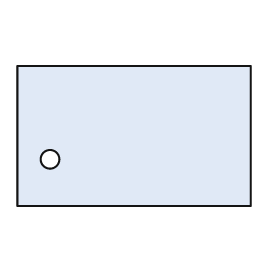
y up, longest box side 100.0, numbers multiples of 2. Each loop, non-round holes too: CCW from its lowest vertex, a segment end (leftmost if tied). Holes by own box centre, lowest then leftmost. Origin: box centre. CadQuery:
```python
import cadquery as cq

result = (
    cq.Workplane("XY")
    .moveTo(-50.0, -30.0)
    .lineTo(50.0, -30.0)
    .lineTo(50.0, 30.0)
    .lineTo(-50.0, 30.0)
    .close()
    .moveTo(-36.0, -10.0)
    .circle(4.0)
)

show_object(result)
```